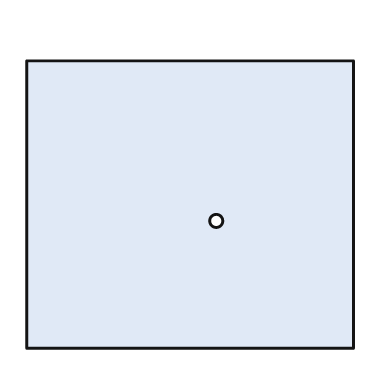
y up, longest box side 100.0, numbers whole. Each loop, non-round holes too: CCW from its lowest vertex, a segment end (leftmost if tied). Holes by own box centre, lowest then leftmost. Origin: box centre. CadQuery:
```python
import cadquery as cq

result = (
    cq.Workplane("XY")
    .moveTo(-50.0, -44.0)
    .lineTo(50.0, -44.0)
    .lineTo(50.0, 44.0)
    .lineTo(-50.0, 44.0)
    .close()
    .moveTo(8.0, -5.0)
    .circle(2.0)
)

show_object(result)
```